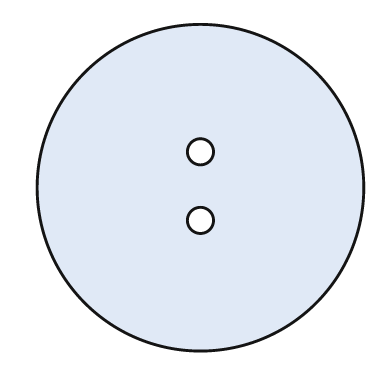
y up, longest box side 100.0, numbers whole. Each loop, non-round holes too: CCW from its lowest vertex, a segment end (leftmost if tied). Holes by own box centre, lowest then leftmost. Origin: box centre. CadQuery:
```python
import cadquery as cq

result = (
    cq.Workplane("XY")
    .moveTo(0.0, 0.0)
    .circle(50.0)
    .moveTo(0.0, -10.0)
    .circle(4.0)
    .moveTo(0.0, 11.0)
    .circle(4.0)
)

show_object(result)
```